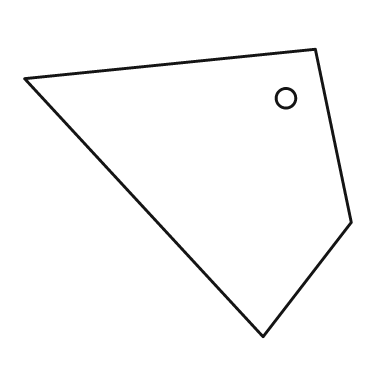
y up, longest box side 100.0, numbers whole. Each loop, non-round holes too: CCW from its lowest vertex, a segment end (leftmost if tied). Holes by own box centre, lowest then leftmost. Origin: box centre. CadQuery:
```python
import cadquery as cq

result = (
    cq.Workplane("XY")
    .moveTo(23.0, -44.0)
    .lineTo(50.0, -9.0)
    .lineTo(39.0, 44.0)
    .lineTo(-50.0, 35.0)
    .close()
    .moveTo(30.0, 29.0)
    .circle(3.0)
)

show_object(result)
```